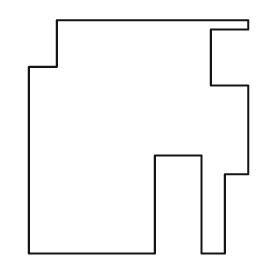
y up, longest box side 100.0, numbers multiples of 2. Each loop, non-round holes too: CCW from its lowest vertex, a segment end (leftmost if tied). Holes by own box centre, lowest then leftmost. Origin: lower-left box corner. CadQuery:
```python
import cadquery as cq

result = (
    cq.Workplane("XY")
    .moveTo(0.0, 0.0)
    .lineTo(54.0, 0.0)
    .lineTo(54.0, 42.0)
    .lineTo(74.0, 42.0)
    .lineTo(74.0, 0.0)
    .lineTo(84.0, 0.0)
    .lineTo(84.0, 34.0)
    .lineTo(94.0, 34.0)
    .lineTo(94.0, 72.0)
    .lineTo(78.0, 72.0)
    .lineTo(78.0, 96.0)
    .lineTo(94.0, 96.0)
    .lineTo(94.0, 100.0)
    .lineTo(12.0, 100.0)
    .lineTo(12.0, 80.0)
    .lineTo(0.0, 80.0)
    .close()
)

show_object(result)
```